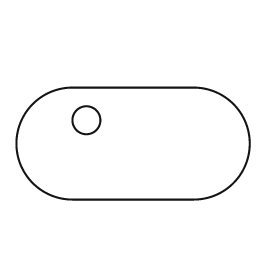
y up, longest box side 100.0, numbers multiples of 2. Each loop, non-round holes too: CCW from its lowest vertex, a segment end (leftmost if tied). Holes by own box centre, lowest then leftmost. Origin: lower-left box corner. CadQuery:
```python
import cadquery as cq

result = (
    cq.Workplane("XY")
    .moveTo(24.0, 0.0)
    .lineTo(76.0, 0.0)
    .threePointArc((100.0, 24.0), (76.0, 48.0))
    .lineTo(24.0, 48.0)
    .threePointArc((0.0, 24.0), (24.0, 0.0))
    .close()
    .moveTo(30.0, 34.0)
    .circle(6.0)
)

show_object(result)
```